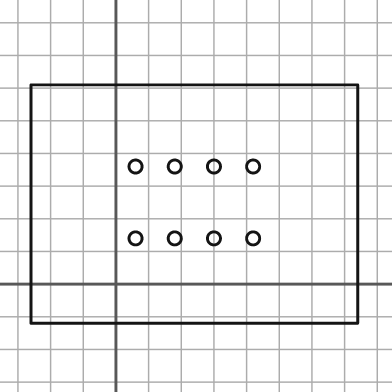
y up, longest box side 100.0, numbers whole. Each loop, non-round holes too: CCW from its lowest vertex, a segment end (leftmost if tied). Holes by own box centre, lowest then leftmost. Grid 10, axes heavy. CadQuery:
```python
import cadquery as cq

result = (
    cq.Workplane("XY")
    .moveTo(-26.0, -12.0)
    .lineTo(74.0, -12.0)
    .lineTo(74.0, 61.0)
    .lineTo(-26.0, 61.0)
    .close()
    .moveTo(6.0, 14.0)
    .circle(2.0)
    .moveTo(18.0, 14.0)
    .circle(2.0)
    .moveTo(30.0, 14.0)
    .circle(2.0)
    .moveTo(42.0, 14.0)
    .circle(2.0)
    .moveTo(6.0, 36.0)
    .circle(2.0)
    .moveTo(18.0, 36.0)
    .circle(2.0)
    .moveTo(30.0, 36.0)
    .circle(2.0)
    .moveTo(42.0, 36.0)
    .circle(2.0)
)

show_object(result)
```